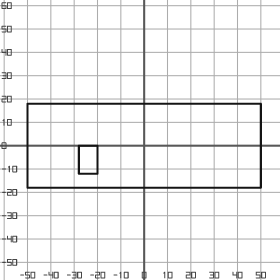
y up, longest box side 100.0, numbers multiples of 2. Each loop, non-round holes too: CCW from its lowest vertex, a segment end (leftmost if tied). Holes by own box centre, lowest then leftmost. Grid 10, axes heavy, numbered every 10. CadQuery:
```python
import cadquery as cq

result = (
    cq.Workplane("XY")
    .moveTo(-50.0, -18.0)
    .lineTo(50.0, -18.0)
    .lineTo(50.0, 18.0)
    .lineTo(-50.0, 18.0)
    .close()
    .moveTo(-28.0, -12.0)
    .lineTo(-20.0, -12.0)
    .lineTo(-20.0, 0.0)
    .lineTo(-28.0, 0.0)
    .close()
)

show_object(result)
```